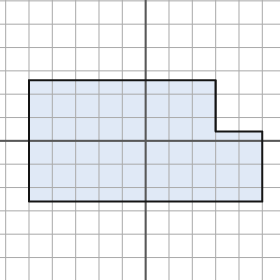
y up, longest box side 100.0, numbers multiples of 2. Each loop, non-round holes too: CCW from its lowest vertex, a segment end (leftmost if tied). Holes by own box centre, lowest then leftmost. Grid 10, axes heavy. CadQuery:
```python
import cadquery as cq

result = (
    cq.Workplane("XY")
    .moveTo(-50.0, -26.0)
    .lineTo(50.0, -26.0)
    .lineTo(50.0, 4.0)
    .lineTo(30.0, 4.0)
    .lineTo(30.0, 26.0)
    .lineTo(-50.0, 26.0)
    .close()
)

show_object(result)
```